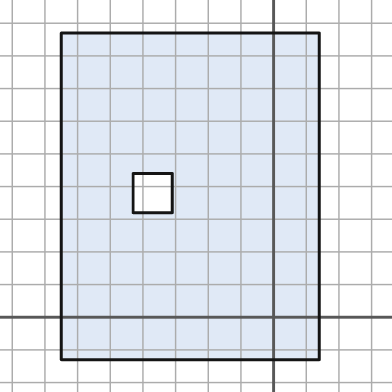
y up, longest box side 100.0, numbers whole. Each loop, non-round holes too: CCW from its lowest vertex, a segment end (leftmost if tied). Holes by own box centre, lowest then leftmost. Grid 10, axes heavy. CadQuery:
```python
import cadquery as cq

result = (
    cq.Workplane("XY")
    .moveTo(-65.0, -13.0)
    .lineTo(14.0, -13.0)
    .lineTo(14.0, 87.0)
    .lineTo(-65.0, 87.0)
    .close()
    .moveTo(-43.0, 32.0)
    .lineTo(-31.0, 32.0)
    .lineTo(-31.0, 44.0)
    .lineTo(-43.0, 44.0)
    .close()
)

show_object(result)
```